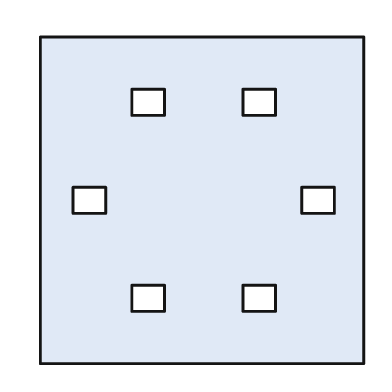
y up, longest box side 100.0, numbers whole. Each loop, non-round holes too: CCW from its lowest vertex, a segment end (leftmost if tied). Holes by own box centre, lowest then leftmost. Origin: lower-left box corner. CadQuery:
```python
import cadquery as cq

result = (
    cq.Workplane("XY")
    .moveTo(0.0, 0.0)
    .lineTo(99.0, 0.0)
    .lineTo(99.0, 100.0)
    .lineTo(0.0, 100.0)
    .close()
    .moveTo(28.0, 16.0)
    .lineTo(38.0, 16.0)
    .lineTo(38.0, 24.0)
    .lineTo(28.0, 24.0)
    .close()
    .moveTo(62.0, 16.0)
    .lineTo(72.0, 16.0)
    .lineTo(72.0, 24.0)
    .lineTo(62.0, 24.0)
    .close()
    .moveTo(10.0, 46.0)
    .lineTo(20.0, 46.0)
    .lineTo(20.0, 54.0)
    .lineTo(10.0, 54.0)
    .close()
    .moveTo(80.0, 46.0)
    .lineTo(90.0, 46.0)
    .lineTo(90.0, 54.0)
    .lineTo(80.0, 54.0)
    .close()
    .moveTo(28.0, 76.0)
    .lineTo(38.0, 76.0)
    .lineTo(38.0, 84.0)
    .lineTo(28.0, 84.0)
    .close()
    .moveTo(62.0, 76.0)
    .lineTo(72.0, 76.0)
    .lineTo(72.0, 84.0)
    .lineTo(62.0, 84.0)
    .close()
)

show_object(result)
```